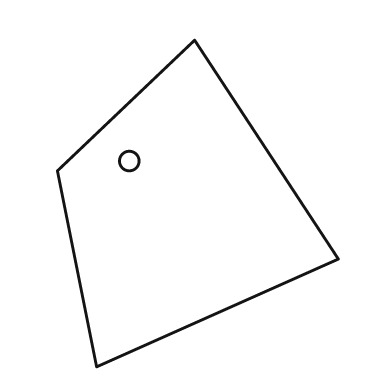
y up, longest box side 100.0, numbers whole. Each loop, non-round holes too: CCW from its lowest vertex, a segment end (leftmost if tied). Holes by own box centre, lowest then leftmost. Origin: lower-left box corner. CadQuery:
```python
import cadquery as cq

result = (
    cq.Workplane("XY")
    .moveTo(12.0, 0.0)
    .lineTo(86.0, 33.0)
    .lineTo(42.0, 100.0)
    .lineTo(0.0, 60.0)
    .close()
    .moveTo(22.0, 63.0)
    .circle(3.0)
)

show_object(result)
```